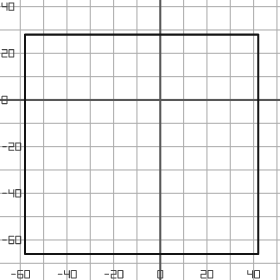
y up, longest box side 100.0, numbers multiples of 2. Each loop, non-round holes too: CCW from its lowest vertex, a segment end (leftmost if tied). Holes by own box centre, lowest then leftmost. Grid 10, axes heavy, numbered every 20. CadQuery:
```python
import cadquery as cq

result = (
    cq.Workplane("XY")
    .moveTo(-58.0, -66.0)
    .lineTo(42.0, -66.0)
    .lineTo(42.0, 28.0)
    .lineTo(-58.0, 28.0)
    .close()
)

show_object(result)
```